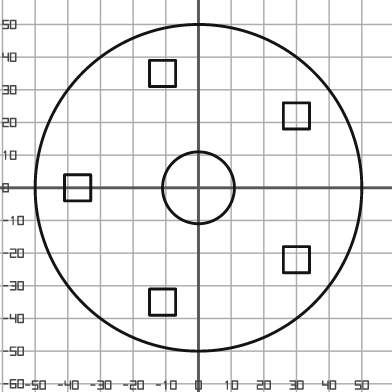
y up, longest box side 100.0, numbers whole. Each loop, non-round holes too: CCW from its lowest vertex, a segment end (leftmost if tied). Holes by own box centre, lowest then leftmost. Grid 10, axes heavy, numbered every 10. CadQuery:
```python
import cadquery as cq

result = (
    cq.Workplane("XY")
    .moveTo(0.0, 0.0)
    .circle(50.0)
    .moveTo(-15.0, -39.0)
    .lineTo(-7.0, -39.0)
    .lineTo(-7.0, -31.0)
    .lineTo(-15.0, -31.0)
    .close()
    .moveTo(26.0, -26.0)
    .lineTo(34.0, -26.0)
    .lineTo(34.0, -18.0)
    .lineTo(26.0, -18.0)
    .close()
    .moveTo(-41.0, -4.0)
    .lineTo(-33.0, -4.0)
    .lineTo(-33.0, 4.0)
    .lineTo(-41.0, 4.0)
    .close()
    .moveTo(0.0, 0.0)
    .circle(11.0)
    .moveTo(26.0, 18.0)
    .lineTo(34.0, 18.0)
    .lineTo(34.0, 26.0)
    .lineTo(26.0, 26.0)
    .close()
    .moveTo(-15.0, 31.0)
    .lineTo(-7.0, 31.0)
    .lineTo(-7.0, 39.0)
    .lineTo(-15.0, 39.0)
    .close()
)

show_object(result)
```